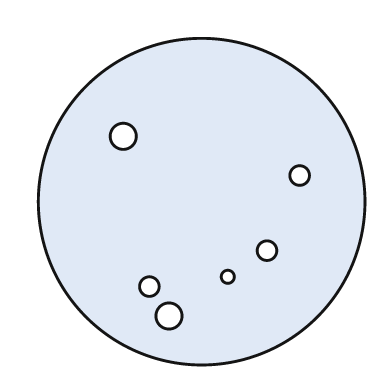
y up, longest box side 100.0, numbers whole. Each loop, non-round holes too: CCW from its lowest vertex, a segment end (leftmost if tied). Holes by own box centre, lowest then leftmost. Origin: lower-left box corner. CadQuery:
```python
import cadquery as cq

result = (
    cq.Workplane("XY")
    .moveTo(50.0, 50.0)
    .circle(50.0)
    .moveTo(40.0, 15.0)
    .circle(4.0)
    .moveTo(34.0, 24.0)
    .circle(3.0)
    .moveTo(58.0, 27.0)
    .circle(2.0)
    .moveTo(70.0, 35.0)
    .circle(3.0)
    .moveTo(80.0, 58.0)
    .circle(3.0)
    .moveTo(26.0, 70.0)
    .circle(4.0)
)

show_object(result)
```